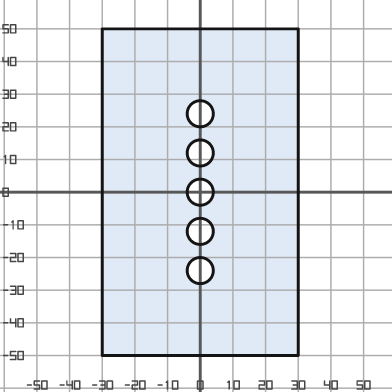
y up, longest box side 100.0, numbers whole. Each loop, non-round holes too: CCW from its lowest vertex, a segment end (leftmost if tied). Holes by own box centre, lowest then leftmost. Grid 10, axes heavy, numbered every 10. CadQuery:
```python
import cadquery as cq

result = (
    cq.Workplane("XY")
    .moveTo(-30.0, -50.0)
    .lineTo(30.0, -50.0)
    .lineTo(30.0, 50.0)
    .lineTo(-30.0, 50.0)
    .close()
    .moveTo(0.0, -24.0)
    .circle(4.0)
    .moveTo(0.0, -12.0)
    .circle(4.0)
    .moveTo(0.0, 0.0)
    .circle(4.0)
    .moveTo(0.0, 12.0)
    .circle(4.0)
    .moveTo(0.0, 24.0)
    .circle(4.0)
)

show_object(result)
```